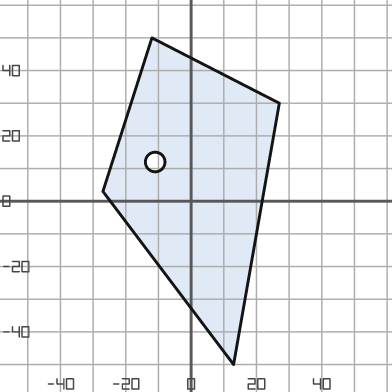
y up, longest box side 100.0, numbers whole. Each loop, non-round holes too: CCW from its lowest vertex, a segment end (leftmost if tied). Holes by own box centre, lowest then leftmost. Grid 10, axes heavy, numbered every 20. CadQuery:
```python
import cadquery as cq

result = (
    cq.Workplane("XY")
    .moveTo(13.0, -50.0)
    .lineTo(27.0, 30.0)
    .lineTo(-12.0, 50.0)
    .lineTo(-27.0, 3.0)
    .close()
    .moveTo(-11.0, 12.0)
    .circle(3.0)
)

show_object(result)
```